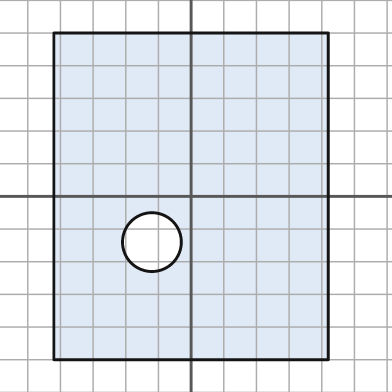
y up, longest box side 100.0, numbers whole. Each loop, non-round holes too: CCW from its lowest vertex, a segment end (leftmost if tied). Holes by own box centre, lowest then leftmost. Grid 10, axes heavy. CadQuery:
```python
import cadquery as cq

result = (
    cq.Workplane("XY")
    .moveTo(-42.0, -50.0)
    .lineTo(42.0, -50.0)
    .lineTo(42.0, 50.0)
    .lineTo(-42.0, 50.0)
    .close()
    .moveTo(-12.0, -14.0)
    .circle(9.0)
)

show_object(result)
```